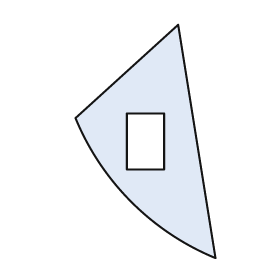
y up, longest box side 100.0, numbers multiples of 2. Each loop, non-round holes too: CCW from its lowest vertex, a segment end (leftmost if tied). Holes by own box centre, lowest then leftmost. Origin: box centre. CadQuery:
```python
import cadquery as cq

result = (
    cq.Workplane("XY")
    .moveTo(30.0, -50.0)
    .lineTo(14.0, 50.0)
    .lineTo(-30.0, 10.0)
    .threePointArc((-6.0, -26.0), (30.0, -50.0))
    .close()
    .moveTo(-8.0, -12.0)
    .lineTo(8.0, -12.0)
    .lineTo(8.0, 12.0)
    .lineTo(-8.0, 12.0)
    .close()
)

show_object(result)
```